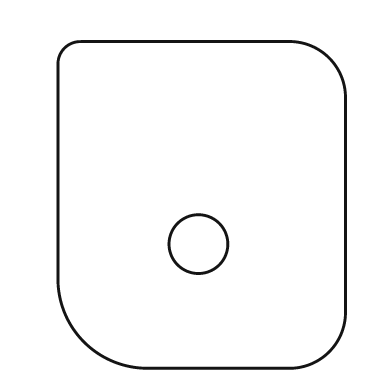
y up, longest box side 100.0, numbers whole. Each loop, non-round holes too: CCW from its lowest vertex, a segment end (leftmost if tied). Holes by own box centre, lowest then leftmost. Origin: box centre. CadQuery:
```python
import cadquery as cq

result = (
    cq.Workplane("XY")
    .moveTo(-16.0, -50.0)
    .lineTo(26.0, -50.0)
    .threePointArc((39.0, -45.0), (44.0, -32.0))
    .lineTo(44.0, 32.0)
    .threePointArc((39.0, 45.0), (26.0, 50.0))
    .lineTo(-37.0, 50.0)
    .threePointArc((-42.0, 48.0), (-44.0, 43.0))
    .lineTo(-44.0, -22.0)
    .threePointArc((-36.0, -42.0), (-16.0, -50.0))
    .close()
    .moveTo(-1.0, -12.0)
    .circle(9.0)
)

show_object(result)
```